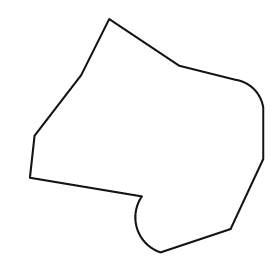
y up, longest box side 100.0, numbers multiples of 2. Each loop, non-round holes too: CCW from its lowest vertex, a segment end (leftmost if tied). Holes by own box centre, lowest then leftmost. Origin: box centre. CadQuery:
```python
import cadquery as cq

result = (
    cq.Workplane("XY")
    .moveTo(6.0, -50.0)
    .lineTo(36.0, -40.0)
    .lineTo(50.0, -10.0)
    .lineTo(50.0, 12.0)
    .threePointArc((46.0, 20.0), (38.0, 24.0))
    .lineTo(14.0, 30.0)
    .lineTo(-16.0, 50.0)
    .lineTo(-28.0, 26.0)
    .lineTo(-48.0, 0.0)
    .lineTo(-50.0, -18.0)
    .lineTo(-2.0, -26.0)
    .threePointArc((-4.0, -40.0), (6.0, -50.0))
    .close()
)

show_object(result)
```